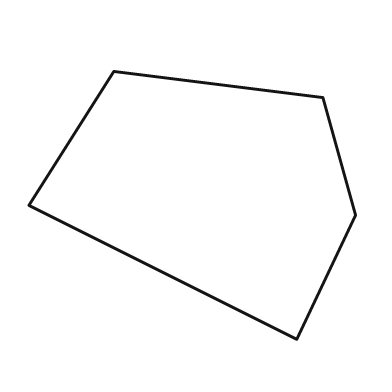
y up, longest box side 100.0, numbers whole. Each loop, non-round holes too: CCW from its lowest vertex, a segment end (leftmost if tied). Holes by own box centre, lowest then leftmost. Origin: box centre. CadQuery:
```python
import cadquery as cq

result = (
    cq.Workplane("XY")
    .moveTo(32.0, -41.0)
    .lineTo(50.0, -3.0)
    .lineTo(40.0, 33.0)
    .lineTo(-24.0, 41.0)
    .lineTo(-50.0, 0.0)
    .close()
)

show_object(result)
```